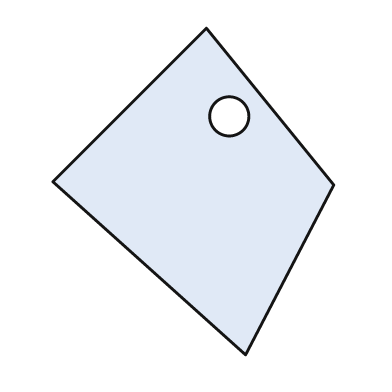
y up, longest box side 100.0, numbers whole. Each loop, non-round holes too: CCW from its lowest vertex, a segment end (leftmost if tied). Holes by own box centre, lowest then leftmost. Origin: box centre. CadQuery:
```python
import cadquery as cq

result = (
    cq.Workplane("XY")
    .moveTo(16.0, -50.0)
    .lineTo(43.0, 2.0)
    .lineTo(4.0, 50.0)
    .lineTo(-43.0, 3.0)
    .close()
    .moveTo(11.0, 23.0)
    .circle(6.0)
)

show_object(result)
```